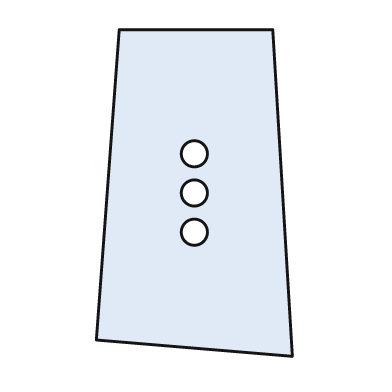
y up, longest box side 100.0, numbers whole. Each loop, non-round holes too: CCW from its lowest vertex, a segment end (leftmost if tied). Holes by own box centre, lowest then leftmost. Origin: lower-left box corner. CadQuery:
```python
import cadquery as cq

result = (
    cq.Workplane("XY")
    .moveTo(60.0, 0.0)
    .lineTo(54.0, 100.0)
    .lineTo(7.0, 100.0)
    .lineTo(0.0, 5.0)
    .close()
    .moveTo(30.0, 38.0)
    .circle(4.0)
    .moveTo(30.0, 50.0)
    .circle(4.0)
    .moveTo(30.0, 62.0)
    .circle(4.0)
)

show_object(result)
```